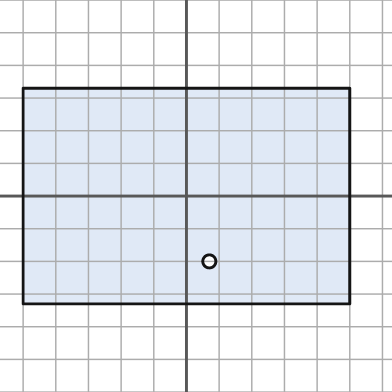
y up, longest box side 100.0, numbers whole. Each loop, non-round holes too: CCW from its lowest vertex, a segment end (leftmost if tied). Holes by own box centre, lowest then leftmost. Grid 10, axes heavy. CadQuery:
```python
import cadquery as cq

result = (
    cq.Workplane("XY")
    .moveTo(-50.0, -33.0)
    .lineTo(50.0, -33.0)
    .lineTo(50.0, 33.0)
    .lineTo(-50.0, 33.0)
    .close()
    .moveTo(7.0, -20.0)
    .circle(2.0)
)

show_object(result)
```